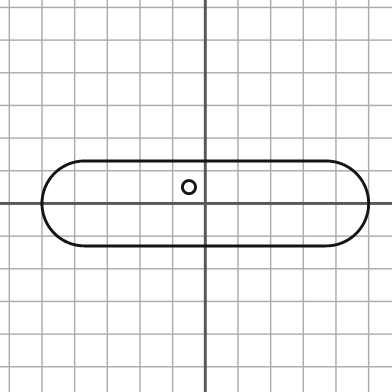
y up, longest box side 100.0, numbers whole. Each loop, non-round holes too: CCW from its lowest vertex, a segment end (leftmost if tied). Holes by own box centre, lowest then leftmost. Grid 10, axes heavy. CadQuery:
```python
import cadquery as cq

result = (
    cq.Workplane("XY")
    .moveTo(-37.0, -13.0)
    .lineTo(37.0, -13.0)
    .threePointArc((50.0, 0.0), (37.0, 13.0))
    .lineTo(-37.0, 13.0)
    .threePointArc((-50.0, 0.0), (-37.0, -13.0))
    .close()
    .moveTo(-5.0, 5.0)
    .circle(2.0)
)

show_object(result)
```